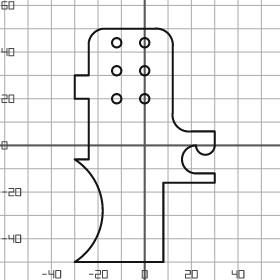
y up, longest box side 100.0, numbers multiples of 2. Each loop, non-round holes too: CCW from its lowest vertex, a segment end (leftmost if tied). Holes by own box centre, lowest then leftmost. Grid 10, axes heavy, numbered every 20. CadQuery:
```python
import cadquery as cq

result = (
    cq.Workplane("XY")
    .moveTo(-30.0, -50.0)
    .lineTo(8.0, -50.0)
    .lineTo(8.0, -16.0)
    .lineTo(30.0, -16.0)
    .lineTo(30.0, -12.0)
    .lineTo(22.0, -12.0)
    .threePointArc((16.0, -6.0), (22.0, 0.0))
    .threePointArc((26.0, -4.0), (30.0, 0.0))
    .lineTo(30.0, 6.0)
    .lineTo(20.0, 6.0)
    .threePointArc((14.0, 8.0), (12.0, 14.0))
    .lineTo(12.0, 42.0)
    .threePointArc((10.0, 48.0), (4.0, 50.0))
    .lineTo(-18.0, 50.0)
    .threePointArc((-22.0, 48.0), (-24.0, 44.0))
    .lineTo(-24.0, 30.0)
    .lineTo(-30.0, 30.0)
    .lineTo(-30.0, 20.0)
    .lineTo(-24.0, 20.0)
    .lineTo(-24.0, -6.0)
    .lineTo(-30.0, -6.0)
    .threePointArc((-18.0, -28.0), (-30.0, -50.0))
    .close()
    .moveTo(-12.0, 20.0)
    .circle(2.0)
    .moveTo(0.0, 20.0)
    .circle(2.0)
    .moveTo(-12.0, 32.0)
    .circle(2.0)
    .moveTo(0.0, 32.0)
    .circle(2.0)
    .moveTo(-12.0, 44.0)
    .circle(2.0)
    .moveTo(0.0, 44.0)
    .circle(2.0)
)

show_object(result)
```